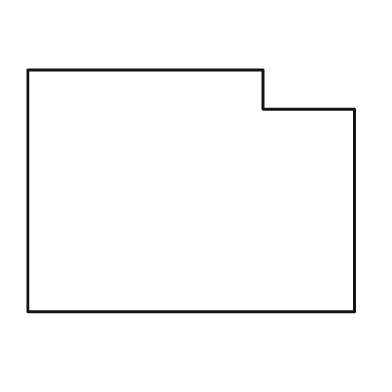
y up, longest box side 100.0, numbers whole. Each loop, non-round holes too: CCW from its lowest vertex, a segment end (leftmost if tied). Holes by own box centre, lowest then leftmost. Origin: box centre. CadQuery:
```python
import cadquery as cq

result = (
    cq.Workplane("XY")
    .moveTo(-50.0, -37.0)
    .lineTo(50.0, -37.0)
    .lineTo(50.0, 25.0)
    .lineTo(22.0, 25.0)
    .lineTo(22.0, 37.0)
    .lineTo(-50.0, 37.0)
    .close()
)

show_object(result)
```